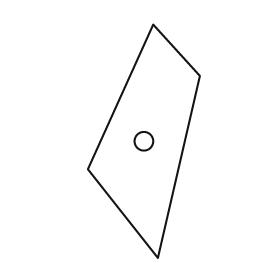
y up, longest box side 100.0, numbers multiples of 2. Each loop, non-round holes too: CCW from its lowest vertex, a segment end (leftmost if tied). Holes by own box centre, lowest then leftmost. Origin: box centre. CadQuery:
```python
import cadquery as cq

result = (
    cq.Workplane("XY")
    .moveTo(6.0, -50.0)
    .lineTo(24.0, 28.0)
    .lineTo(4.0, 50.0)
    .lineTo(-24.0, -12.0)
    .close()
    .moveTo(0.0, 0.0)
    .circle(4.0)
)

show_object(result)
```